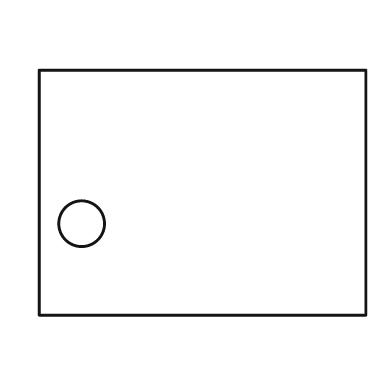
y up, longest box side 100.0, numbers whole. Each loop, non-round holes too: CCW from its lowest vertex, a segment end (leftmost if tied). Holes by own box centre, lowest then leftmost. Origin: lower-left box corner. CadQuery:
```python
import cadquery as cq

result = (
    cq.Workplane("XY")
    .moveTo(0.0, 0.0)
    .lineTo(100.0, 0.0)
    .lineTo(100.0, 75.0)
    .lineTo(0.0, 75.0)
    .close()
    .moveTo(13.0, 28.0)
    .circle(7.0)
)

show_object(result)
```